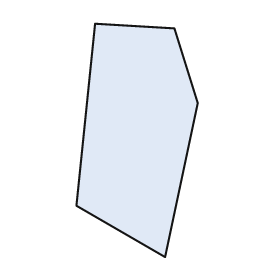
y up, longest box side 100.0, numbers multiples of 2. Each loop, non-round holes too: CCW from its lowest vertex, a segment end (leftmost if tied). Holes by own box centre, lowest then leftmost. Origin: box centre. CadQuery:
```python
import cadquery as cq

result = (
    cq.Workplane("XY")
    .moveTo(12.0, -50.0)
    .lineTo(26.0, 16.0)
    .lineTo(16.0, 48.0)
    .lineTo(-18.0, 50.0)
    .lineTo(-26.0, -28.0)
    .close()
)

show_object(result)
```